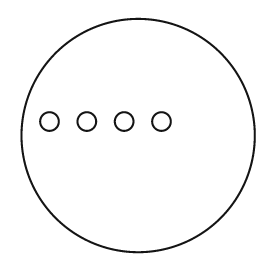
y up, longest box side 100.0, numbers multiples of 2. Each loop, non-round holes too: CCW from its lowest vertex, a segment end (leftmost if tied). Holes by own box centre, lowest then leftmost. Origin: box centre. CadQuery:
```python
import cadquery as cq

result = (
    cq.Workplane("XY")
    .moveTo(0.0, 0.0)
    .circle(50.0)
    .moveTo(-38.0, 6.0)
    .circle(4.0)
    .moveTo(-22.0, 6.0)
    .circle(4.0)
    .moveTo(-6.0, 6.0)
    .circle(4.0)
    .moveTo(10.0, 6.0)
    .circle(4.0)
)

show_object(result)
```